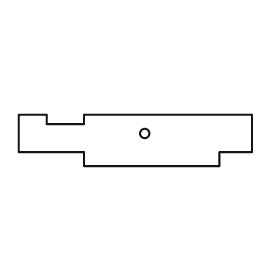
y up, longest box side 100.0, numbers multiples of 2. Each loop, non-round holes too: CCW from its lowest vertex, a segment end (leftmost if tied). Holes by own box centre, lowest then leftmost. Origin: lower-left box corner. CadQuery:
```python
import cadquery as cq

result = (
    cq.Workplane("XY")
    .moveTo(28.0, 0.0)
    .lineTo(86.0, 0.0)
    .lineTo(86.0, 6.0)
    .lineTo(100.0, 6.0)
    .lineTo(100.0, 22.0)
    .lineTo(28.0, 22.0)
    .lineTo(28.0, 18.0)
    .lineTo(12.0, 18.0)
    .lineTo(12.0, 22.0)
    .lineTo(0.0, 22.0)
    .lineTo(0.0, 6.0)
    .lineTo(28.0, 6.0)
    .close()
    .moveTo(54.0, 14.0)
    .circle(2.0)
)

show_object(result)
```